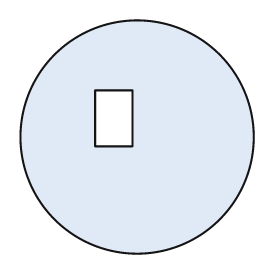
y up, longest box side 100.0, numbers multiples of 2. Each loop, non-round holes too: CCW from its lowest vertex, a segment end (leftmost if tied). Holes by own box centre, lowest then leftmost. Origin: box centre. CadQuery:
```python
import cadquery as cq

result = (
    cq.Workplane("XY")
    .moveTo(0.0, 0.0)
    .circle(50.0)
    .moveTo(-18.0, -4.0)
    .lineTo(-2.0, -4.0)
    .lineTo(-2.0, 20.0)
    .lineTo(-18.0, 20.0)
    .close()
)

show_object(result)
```